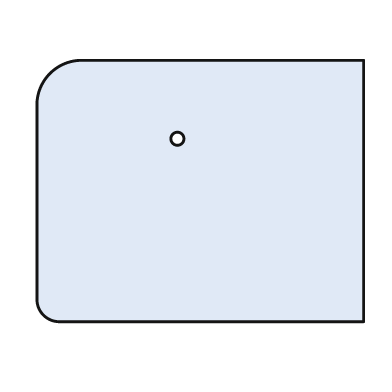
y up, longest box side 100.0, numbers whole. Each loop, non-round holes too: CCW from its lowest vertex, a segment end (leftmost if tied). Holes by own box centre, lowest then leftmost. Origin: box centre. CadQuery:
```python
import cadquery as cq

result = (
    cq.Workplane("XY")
    .moveTo(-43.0, -40.0)
    .lineTo(50.0, -40.0)
    .lineTo(50.0, 40.0)
    .lineTo(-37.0, 40.0)
    .threePointArc((-46.0, 36.0), (-50.0, 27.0))
    .lineTo(-50.0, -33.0)
    .threePointArc((-48.0, -38.0), (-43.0, -40.0))
    .close()
    .moveTo(-7.0, 16.0)
    .circle(2.0)
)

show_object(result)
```